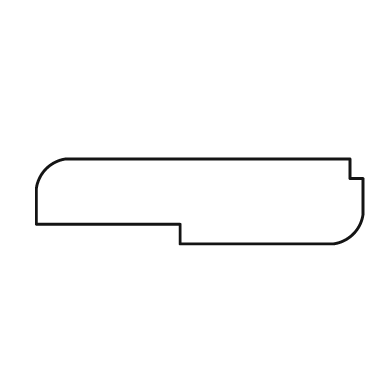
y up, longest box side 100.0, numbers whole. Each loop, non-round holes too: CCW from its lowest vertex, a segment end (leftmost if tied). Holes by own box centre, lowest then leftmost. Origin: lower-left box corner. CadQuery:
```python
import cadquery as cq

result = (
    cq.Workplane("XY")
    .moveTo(44.0, 0.0)
    .lineTo(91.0, 0.0)
    .threePointArc((97.0, 3.0), (100.0, 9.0))
    .lineTo(100.0, 20.0)
    .lineTo(96.0, 20.0)
    .lineTo(96.0, 26.0)
    .lineTo(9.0, 26.0)
    .threePointArc((3.0, 23.0), (0.0, 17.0))
    .lineTo(0.0, 6.0)
    .lineTo(44.0, 6.0)
    .close()
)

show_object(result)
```